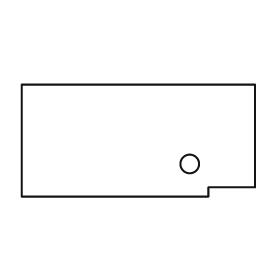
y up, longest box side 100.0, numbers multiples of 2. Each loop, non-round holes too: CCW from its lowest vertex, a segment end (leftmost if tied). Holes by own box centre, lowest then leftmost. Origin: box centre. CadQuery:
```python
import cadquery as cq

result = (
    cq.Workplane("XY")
    .moveTo(-50.0, -24.0)
    .lineTo(30.0, -24.0)
    .lineTo(30.0, -20.0)
    .lineTo(50.0, -20.0)
    .lineTo(50.0, 24.0)
    .lineTo(-50.0, 24.0)
    .close()
    .moveTo(22.0, -10.0)
    .circle(4.0)
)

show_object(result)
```